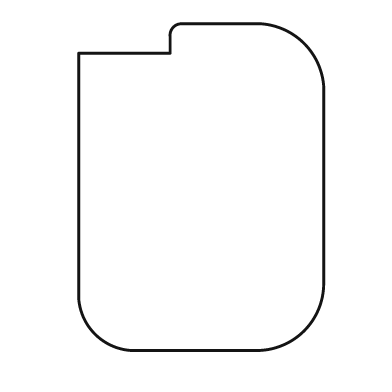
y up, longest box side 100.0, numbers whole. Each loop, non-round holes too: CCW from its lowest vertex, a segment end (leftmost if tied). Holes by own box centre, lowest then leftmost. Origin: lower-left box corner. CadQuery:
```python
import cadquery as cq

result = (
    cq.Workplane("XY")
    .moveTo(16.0, 0.0)
    .lineTo(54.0, 0.0)
    .threePointArc((69.0, 6.0), (75.0, 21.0))
    .lineTo(75.0, 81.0)
    .threePointArc((69.0, 94.0), (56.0, 100.0))
    .lineTo(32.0, 100.0)
    .threePointArc((29.0, 99.0), (28.0, 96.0))
    .lineTo(28.0, 91.0)
    .lineTo(0.0, 91.0)
    .lineTo(0.0, 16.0)
    .threePointArc((5.0, 5.0), (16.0, 0.0))
    .close()
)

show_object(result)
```